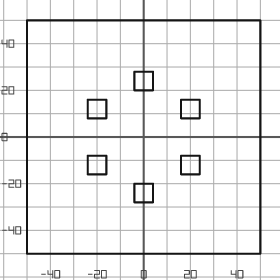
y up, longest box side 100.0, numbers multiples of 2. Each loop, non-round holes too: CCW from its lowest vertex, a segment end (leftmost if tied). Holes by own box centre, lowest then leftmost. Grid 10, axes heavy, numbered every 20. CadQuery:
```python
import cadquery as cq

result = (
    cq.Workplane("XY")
    .moveTo(-50.0, -50.0)
    .lineTo(50.0, -50.0)
    .lineTo(50.0, 50.0)
    .lineTo(-50.0, 50.0)
    .close()
    .moveTo(-4.0, -28.0)
    .lineTo(4.0, -28.0)
    .lineTo(4.0, -20.0)
    .lineTo(-4.0, -20.0)
    .close()
    .moveTo(-24.0, -16.0)
    .lineTo(-16.0, -16.0)
    .lineTo(-16.0, -8.0)
    .lineTo(-24.0, -8.0)
    .close()
    .moveTo(16.0, -16.0)
    .lineTo(24.0, -16.0)
    .lineTo(24.0, -8.0)
    .lineTo(16.0, -8.0)
    .close()
    .moveTo(-24.0, 8.0)
    .lineTo(-16.0, 8.0)
    .lineTo(-16.0, 16.0)
    .lineTo(-24.0, 16.0)
    .close()
    .moveTo(16.0, 8.0)
    .lineTo(24.0, 8.0)
    .lineTo(24.0, 16.0)
    .lineTo(16.0, 16.0)
    .close()
    .moveTo(-4.0, 20.0)
    .lineTo(4.0, 20.0)
    .lineTo(4.0, 28.0)
    .lineTo(-4.0, 28.0)
    .close()
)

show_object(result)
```